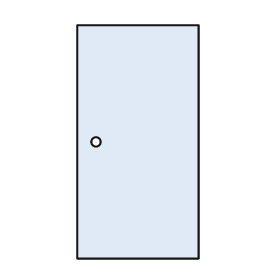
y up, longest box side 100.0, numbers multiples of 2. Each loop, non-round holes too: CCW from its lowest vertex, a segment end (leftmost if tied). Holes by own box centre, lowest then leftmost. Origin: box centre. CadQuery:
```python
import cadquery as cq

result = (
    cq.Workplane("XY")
    .moveTo(-26.0, -50.0)
    .lineTo(26.0, -50.0)
    .lineTo(26.0, 50.0)
    .lineTo(-26.0, 50.0)
    .close()
    .moveTo(-18.0, 0.0)
    .circle(2.0)
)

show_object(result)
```